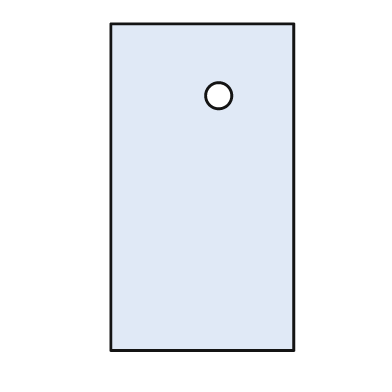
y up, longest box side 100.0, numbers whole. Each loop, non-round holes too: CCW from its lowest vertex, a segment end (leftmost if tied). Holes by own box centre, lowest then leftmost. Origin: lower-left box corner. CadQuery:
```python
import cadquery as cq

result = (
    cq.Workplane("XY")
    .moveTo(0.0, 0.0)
    .lineTo(56.0, 0.0)
    .lineTo(56.0, 100.0)
    .lineTo(0.0, 100.0)
    .close()
    .moveTo(33.0, 78.0)
    .circle(4.0)
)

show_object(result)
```